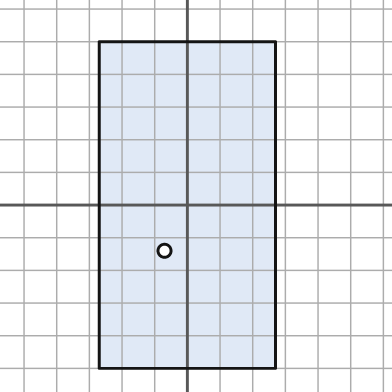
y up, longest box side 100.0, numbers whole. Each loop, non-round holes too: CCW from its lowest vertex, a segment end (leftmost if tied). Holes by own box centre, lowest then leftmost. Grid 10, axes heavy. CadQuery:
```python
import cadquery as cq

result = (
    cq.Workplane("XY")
    .moveTo(-27.0, -50.0)
    .lineTo(27.0, -50.0)
    .lineTo(27.0, 50.0)
    .lineTo(-27.0, 50.0)
    .close()
    .moveTo(-7.0, -14.0)
    .circle(2.0)
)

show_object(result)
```